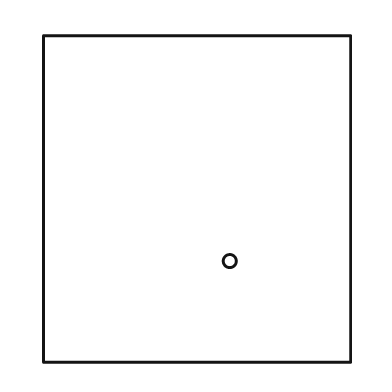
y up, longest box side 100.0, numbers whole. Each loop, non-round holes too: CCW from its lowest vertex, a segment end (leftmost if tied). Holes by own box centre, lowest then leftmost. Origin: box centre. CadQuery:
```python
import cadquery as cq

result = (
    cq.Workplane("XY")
    .moveTo(-47.0, -50.0)
    .lineTo(47.0, -50.0)
    .lineTo(47.0, 50.0)
    .lineTo(-47.0, 50.0)
    .close()
    .moveTo(10.0, -19.0)
    .circle(2.0)
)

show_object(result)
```